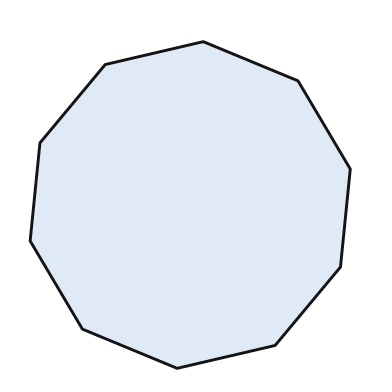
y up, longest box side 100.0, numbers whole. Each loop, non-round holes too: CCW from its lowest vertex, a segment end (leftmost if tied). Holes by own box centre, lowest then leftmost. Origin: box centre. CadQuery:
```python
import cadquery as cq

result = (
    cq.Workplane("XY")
    .moveTo(-4.0, -50.0)
    .lineTo(26.0, -43.0)
    .lineTo(46.0, -19.0)
    .lineTo(49.0, 11.0)
    .lineTo(33.0, 38.0)
    .lineTo(4.0, 50.0)
    .lineTo(-26.0, 43.0)
    .lineTo(-46.0, 19.0)
    .lineTo(-49.0, -11.0)
    .lineTo(-33.0, -38.0)
    .close()
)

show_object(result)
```